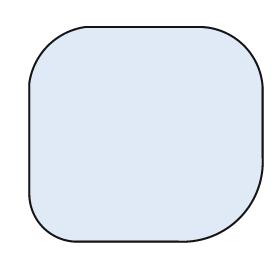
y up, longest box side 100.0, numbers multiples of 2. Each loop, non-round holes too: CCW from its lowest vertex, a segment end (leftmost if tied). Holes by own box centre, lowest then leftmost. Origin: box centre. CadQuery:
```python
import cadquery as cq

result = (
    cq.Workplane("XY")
    .moveTo(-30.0, -46.0)
    .lineTo(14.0, -46.0)
    .threePointArc((40.0, -36.0), (50.0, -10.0))
    .lineTo(50.0, 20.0)
    .threePointArc((42.0, 38.0), (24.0, 46.0))
    .lineTo(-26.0, 46.0)
    .threePointArc((-42.0, 38.0), (-50.0, 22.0))
    .lineTo(-50.0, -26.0)
    .threePointArc((-44.0, -40.0), (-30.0, -46.0))
    .close()
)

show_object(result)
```